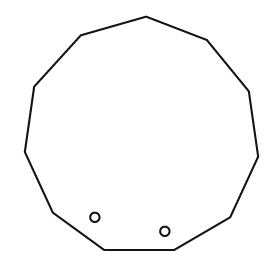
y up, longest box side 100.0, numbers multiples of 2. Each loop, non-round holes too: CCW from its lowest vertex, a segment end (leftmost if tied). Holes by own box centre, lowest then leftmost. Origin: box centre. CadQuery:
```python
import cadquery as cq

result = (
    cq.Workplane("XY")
    .moveTo(-16.0, -50.0)
    .lineTo(14.0, -50.0)
    .lineTo(38.0, -36.0)
    .lineTo(50.0, -10.0)
    .lineTo(46.0, 18.0)
    .lineTo(28.0, 40.0)
    .lineTo(2.0, 50.0)
    .lineTo(-26.0, 42.0)
    .lineTo(-46.0, 20.0)
    .lineTo(-50.0, -8.0)
    .lineTo(-38.0, -34.0)
    .close()
    .moveTo(10.0, -42.0)
    .circle(2.0)
    .moveTo(-20.0, -36.0)
    .circle(2.0)
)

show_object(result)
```